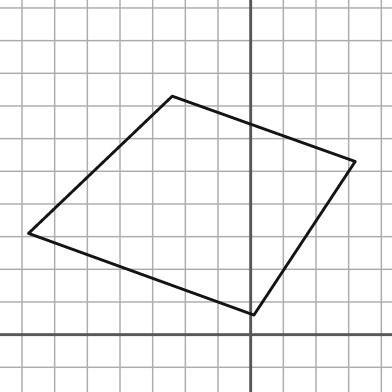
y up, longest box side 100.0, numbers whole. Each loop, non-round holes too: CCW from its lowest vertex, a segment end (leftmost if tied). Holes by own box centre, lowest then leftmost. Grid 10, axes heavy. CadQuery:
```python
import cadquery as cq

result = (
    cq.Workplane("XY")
    .moveTo(1.0, 6.0)
    .lineTo(32.0, 53.0)
    .lineTo(-24.0, 73.0)
    .lineTo(-68.0, 31.0)
    .close()
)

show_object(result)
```